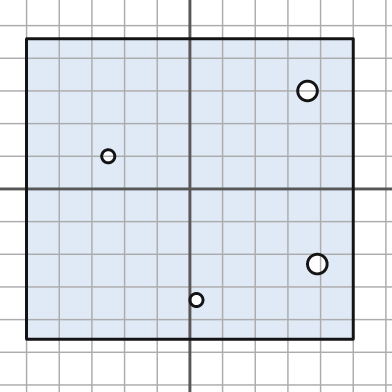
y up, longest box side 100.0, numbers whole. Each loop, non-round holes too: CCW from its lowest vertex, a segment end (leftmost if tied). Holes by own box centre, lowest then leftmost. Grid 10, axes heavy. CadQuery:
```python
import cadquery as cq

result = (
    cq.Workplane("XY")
    .moveTo(-50.0, -46.0)
    .lineTo(50.0, -46.0)
    .lineTo(50.0, 46.0)
    .lineTo(-50.0, 46.0)
    .close()
    .moveTo(2.0, -34.0)
    .circle(2.0)
    .moveTo(39.0, -23.0)
    .circle(3.0)
    .moveTo(-25.0, 10.0)
    .circle(2.0)
    .moveTo(36.0, 30.0)
    .circle(3.0)
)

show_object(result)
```